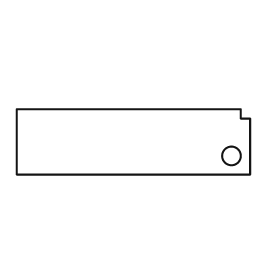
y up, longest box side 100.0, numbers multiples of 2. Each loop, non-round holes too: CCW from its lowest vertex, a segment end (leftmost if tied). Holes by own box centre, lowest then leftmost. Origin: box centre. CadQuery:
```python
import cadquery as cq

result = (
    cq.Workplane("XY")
    .moveTo(-50.0, -14.0)
    .lineTo(50.0, -14.0)
    .lineTo(50.0, 10.0)
    .lineTo(46.0, 10.0)
    .lineTo(46.0, 14.0)
    .lineTo(-50.0, 14.0)
    .close()
    .moveTo(42.0, -6.0)
    .circle(4.0)
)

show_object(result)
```